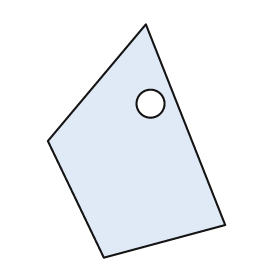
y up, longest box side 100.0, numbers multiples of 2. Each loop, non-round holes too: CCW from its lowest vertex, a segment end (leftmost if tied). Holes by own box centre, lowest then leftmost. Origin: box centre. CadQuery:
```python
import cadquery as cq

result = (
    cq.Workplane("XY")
    .moveTo(-14.0, -50.0)
    .lineTo(38.0, -36.0)
    .lineTo(4.0, 50.0)
    .lineTo(-38.0, 0.0)
    .close()
    .moveTo(6.0, 16.0)
    .circle(6.0)
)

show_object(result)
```